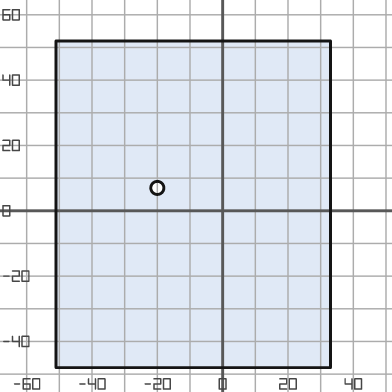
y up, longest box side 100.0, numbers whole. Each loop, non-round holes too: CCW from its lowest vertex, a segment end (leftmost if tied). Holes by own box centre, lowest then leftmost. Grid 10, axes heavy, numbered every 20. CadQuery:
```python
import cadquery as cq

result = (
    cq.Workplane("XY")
    .moveTo(-51.0, -48.0)
    .lineTo(33.0, -48.0)
    .lineTo(33.0, 52.0)
    .lineTo(-51.0, 52.0)
    .close()
    .moveTo(-20.0, 7.0)
    .circle(2.0)
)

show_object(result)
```